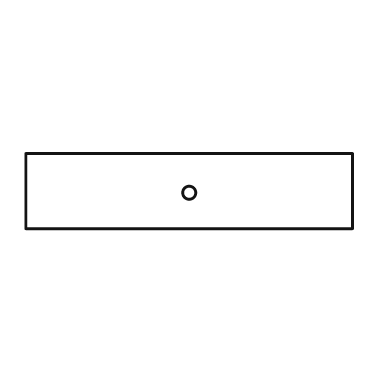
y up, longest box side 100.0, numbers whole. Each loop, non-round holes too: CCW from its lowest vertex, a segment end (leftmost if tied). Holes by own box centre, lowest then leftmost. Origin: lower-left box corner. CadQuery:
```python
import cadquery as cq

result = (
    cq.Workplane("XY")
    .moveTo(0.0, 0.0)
    .lineTo(100.0, 0.0)
    .lineTo(100.0, 23.0)
    .lineTo(0.0, 23.0)
    .close()
    .moveTo(50.0, 11.0)
    .circle(2.0)
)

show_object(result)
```